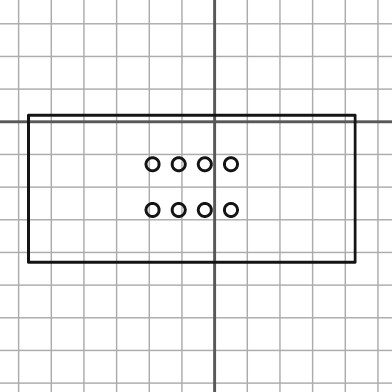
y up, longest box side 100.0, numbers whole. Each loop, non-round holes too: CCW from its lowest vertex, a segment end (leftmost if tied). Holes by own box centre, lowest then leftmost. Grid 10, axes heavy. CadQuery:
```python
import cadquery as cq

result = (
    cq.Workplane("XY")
    .moveTo(-57.0, -43.0)
    .lineTo(43.0, -43.0)
    .lineTo(43.0, 2.0)
    .lineTo(-57.0, 2.0)
    .close()
    .moveTo(-19.0, -27.0)
    .circle(2.0)
    .moveTo(-11.0, -27.0)
    .circle(2.0)
    .moveTo(-3.0, -27.0)
    .circle(2.0)
    .moveTo(5.0, -27.0)
    .circle(2.0)
    .moveTo(-19.0, -13.0)
    .circle(2.0)
    .moveTo(-11.0, -13.0)
    .circle(2.0)
    .moveTo(-3.0, -13.0)
    .circle(2.0)
    .moveTo(5.0, -13.0)
    .circle(2.0)
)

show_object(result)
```